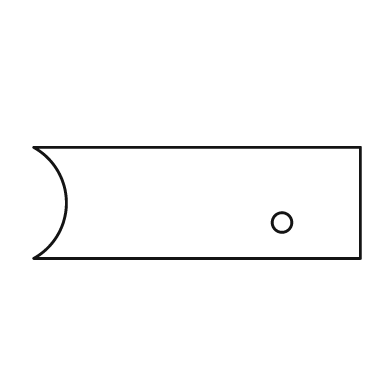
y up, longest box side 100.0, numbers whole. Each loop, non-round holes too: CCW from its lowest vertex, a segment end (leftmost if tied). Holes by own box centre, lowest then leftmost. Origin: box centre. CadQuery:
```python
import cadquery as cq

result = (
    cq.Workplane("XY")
    .moveTo(-50.0, -17.0)
    .lineTo(50.0, -17.0)
    .lineTo(50.0, 17.0)
    .lineTo(-50.0, 17.0)
    .threePointArc((-40.0, 0.0), (-50.0, -17.0))
    .close()
    .moveTo(26.0, -6.0)
    .circle(3.0)
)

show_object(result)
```